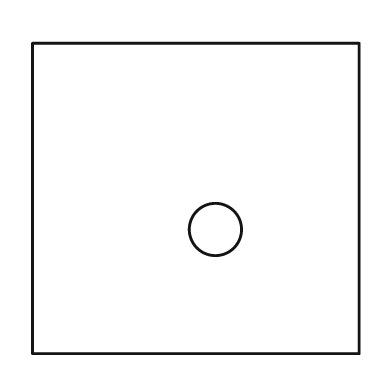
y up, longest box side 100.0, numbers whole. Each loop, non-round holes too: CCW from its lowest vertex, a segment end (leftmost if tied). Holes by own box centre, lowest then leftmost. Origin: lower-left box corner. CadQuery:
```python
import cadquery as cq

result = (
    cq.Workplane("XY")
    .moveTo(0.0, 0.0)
    .lineTo(100.0, 0.0)
    .lineTo(100.0, 95.0)
    .lineTo(0.0, 95.0)
    .close()
    .moveTo(56.0, 38.0)
    .circle(8.0)
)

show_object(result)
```